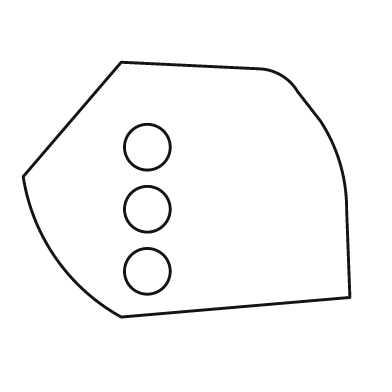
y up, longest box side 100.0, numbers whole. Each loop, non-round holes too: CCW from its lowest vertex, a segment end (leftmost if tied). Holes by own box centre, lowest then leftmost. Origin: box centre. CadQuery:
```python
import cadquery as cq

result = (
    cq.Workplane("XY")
    .moveTo(-20.0, -39.0)
    .lineTo(50.0, -33.0)
    .lineTo(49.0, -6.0)
    .threePointArc((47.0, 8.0), (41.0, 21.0))
    .lineTo(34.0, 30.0)
    .threePointArc((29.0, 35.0), (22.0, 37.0))
    .lineTo(-20.0, 39.0)
    .lineTo(-50.0, 4.0)
    .threePointArc((-40.0, -21.0), (-20.0, -39.0))
    .close()
    .moveTo(-12.0, -25.0)
    .circle(7.0)
    .moveTo(-12.0, -6.0)
    .circle(7.0)
    .moveTo(-12.0, 13.0)
    .circle(7.0)
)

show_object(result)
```